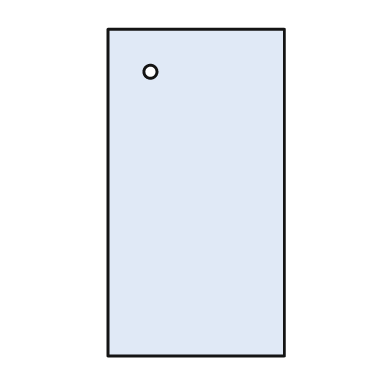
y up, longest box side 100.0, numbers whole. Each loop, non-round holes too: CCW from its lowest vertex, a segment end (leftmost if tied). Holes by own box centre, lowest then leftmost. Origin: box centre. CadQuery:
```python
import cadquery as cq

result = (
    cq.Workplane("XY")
    .moveTo(-27.0, -50.0)
    .lineTo(27.0, -50.0)
    .lineTo(27.0, 50.0)
    .lineTo(-27.0, 50.0)
    .close()
    .moveTo(-14.0, 37.0)
    .circle(2.0)
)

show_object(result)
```